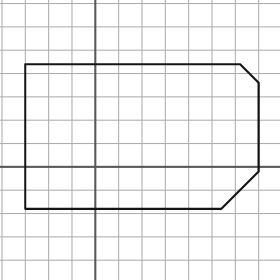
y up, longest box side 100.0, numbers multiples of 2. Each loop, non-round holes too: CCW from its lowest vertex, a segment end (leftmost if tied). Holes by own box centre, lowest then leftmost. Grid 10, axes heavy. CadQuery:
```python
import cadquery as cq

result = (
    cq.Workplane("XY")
    .moveTo(-30.0, -18.0)
    .lineTo(54.0, -18.0)
    .lineTo(70.0, -2.0)
    .lineTo(70.0, 36.0)
    .lineTo(62.0, 44.0)
    .lineTo(-30.0, 44.0)
    .close()
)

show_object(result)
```